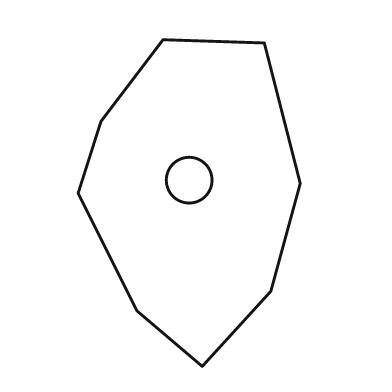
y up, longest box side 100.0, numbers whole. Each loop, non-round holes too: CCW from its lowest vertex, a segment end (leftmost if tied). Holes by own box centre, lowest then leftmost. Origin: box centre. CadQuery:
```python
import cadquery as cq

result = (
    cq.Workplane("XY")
    .moveTo(4.0, -50.0)
    .lineTo(25.0, -27.0)
    .lineTo(34.0, 6.0)
    .lineTo(23.0, 49.0)
    .lineTo(-8.0, 50.0)
    .lineTo(-27.0, 25.0)
    .lineTo(-34.0, 3.0)
    .lineTo(-16.0, -33.0)
    .close()
    .moveTo(0.0, 7.0)
    .circle(7.0)
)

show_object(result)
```